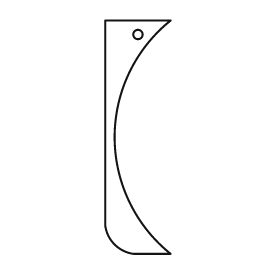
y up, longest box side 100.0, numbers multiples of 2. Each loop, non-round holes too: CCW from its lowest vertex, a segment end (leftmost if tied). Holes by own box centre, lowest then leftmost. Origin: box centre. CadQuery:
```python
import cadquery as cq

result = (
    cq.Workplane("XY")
    .moveTo(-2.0, -50.0)
    .lineTo(14.0, -50.0)
    .threePointArc((-10.0, 0.0), (14.0, 50.0))
    .lineTo(-14.0, 50.0)
    .lineTo(-14.0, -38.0)
    .threePointArc((-10.0, -46.0), (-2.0, -50.0))
    .close()
    .moveTo(0.0, 44.0)
    .circle(2.0)
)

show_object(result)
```